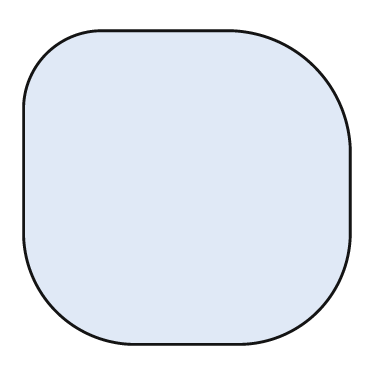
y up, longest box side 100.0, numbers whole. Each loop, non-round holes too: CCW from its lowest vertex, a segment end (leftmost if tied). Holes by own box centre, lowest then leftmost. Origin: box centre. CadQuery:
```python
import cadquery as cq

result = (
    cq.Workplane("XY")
    .moveTo(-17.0, -48.0)
    .lineTo(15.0, -48.0)
    .threePointArc((40.0, -38.0), (50.0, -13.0))
    .lineTo(50.0, 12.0)
    .threePointArc((39.0, 37.0), (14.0, 48.0))
    .lineTo(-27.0, 48.0)
    .threePointArc((-43.0, 41.0), (-50.0, 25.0))
    .lineTo(-50.0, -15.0)
    .threePointArc((-40.0, -38.0), (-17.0, -48.0))
    .close()
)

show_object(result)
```